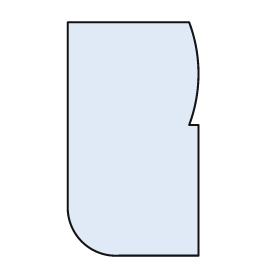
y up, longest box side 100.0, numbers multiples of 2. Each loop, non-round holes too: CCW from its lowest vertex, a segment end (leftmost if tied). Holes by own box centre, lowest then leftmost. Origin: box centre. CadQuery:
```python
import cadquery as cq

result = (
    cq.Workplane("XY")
    .moveTo(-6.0, -50.0)
    .lineTo(28.0, -50.0)
    .lineTo(28.0, 6.0)
    .lineTo(24.0, 6.0)
    .threePointArc((28.0, 28.0), (24.0, 50.0))
    .lineTo(-28.0, 50.0)
    .lineTo(-28.0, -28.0)
    .threePointArc((-22.0, -44.0), (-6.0, -50.0))
    .close()
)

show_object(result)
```